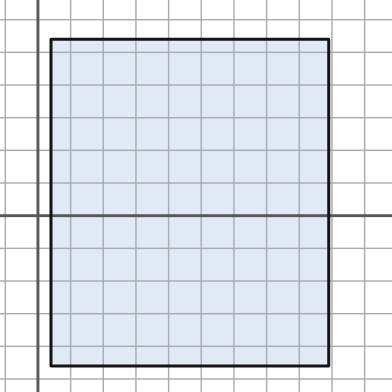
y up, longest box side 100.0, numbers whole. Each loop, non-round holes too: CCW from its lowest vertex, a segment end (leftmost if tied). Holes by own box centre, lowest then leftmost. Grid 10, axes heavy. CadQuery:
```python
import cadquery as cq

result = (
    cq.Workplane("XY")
    .moveTo(4.0, -46.0)
    .lineTo(89.0, -46.0)
    .lineTo(89.0, 54.0)
    .lineTo(4.0, 54.0)
    .close()
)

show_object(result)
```